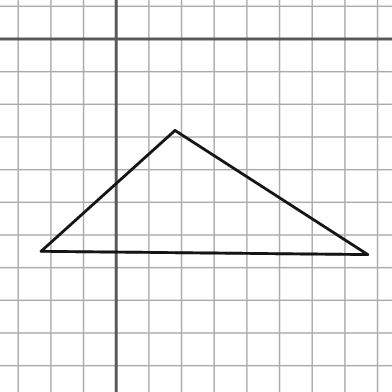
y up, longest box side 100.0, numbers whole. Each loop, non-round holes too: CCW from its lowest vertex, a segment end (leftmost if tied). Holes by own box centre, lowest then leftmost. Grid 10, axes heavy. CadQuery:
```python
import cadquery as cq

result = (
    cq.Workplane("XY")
    .moveTo(77.0, -66.0)
    .lineTo(18.0, -28.0)
    .lineTo(-23.0, -65.0)
    .close()
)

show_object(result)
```